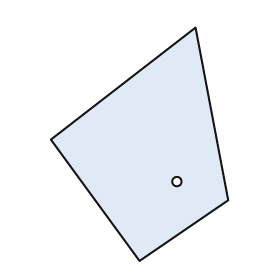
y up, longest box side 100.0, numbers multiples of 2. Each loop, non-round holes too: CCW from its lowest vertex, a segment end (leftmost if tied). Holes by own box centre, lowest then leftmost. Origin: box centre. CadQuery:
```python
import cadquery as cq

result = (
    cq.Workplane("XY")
    .moveTo(0.0, -50.0)
    .lineTo(38.0, -24.0)
    .lineTo(24.0, 50.0)
    .lineTo(-38.0, 2.0)
    .close()
    .moveTo(16.0, -16.0)
    .circle(2.0)
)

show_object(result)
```